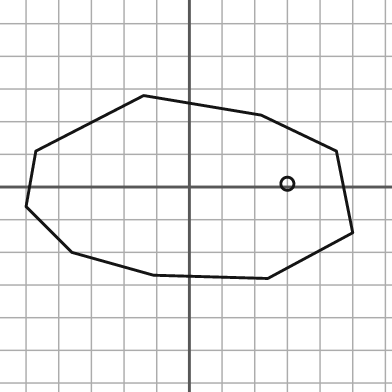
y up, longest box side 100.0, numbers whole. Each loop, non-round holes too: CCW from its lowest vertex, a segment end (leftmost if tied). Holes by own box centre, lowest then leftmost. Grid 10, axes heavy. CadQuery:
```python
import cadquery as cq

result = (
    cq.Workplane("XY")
    .moveTo(24.0, -28.0)
    .lineTo(50.0, -14.0)
    .lineTo(45.0, 11.0)
    .lineTo(22.0, 22.0)
    .lineTo(-14.0, 28.0)
    .lineTo(-47.0, 11.0)
    .lineTo(-50.0, -6.0)
    .lineTo(-36.0, -20.0)
    .lineTo(-11.0, -27.0)
    .close()
    .moveTo(30.0, 1.0)
    .circle(2.0)
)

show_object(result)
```